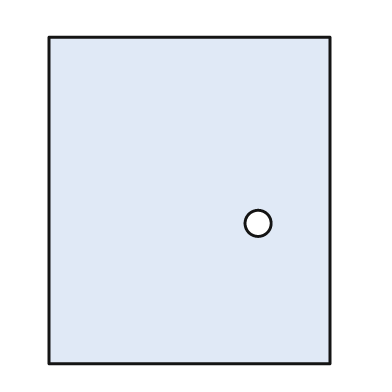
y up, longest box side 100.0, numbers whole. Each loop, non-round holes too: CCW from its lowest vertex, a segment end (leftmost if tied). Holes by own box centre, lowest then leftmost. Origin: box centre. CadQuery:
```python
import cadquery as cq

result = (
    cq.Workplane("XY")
    .moveTo(-43.0, -50.0)
    .lineTo(43.0, -50.0)
    .lineTo(43.0, 50.0)
    .lineTo(-43.0, 50.0)
    .close()
    .moveTo(21.0, -7.0)
    .circle(4.0)
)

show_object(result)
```